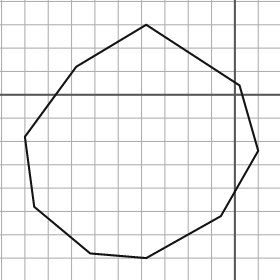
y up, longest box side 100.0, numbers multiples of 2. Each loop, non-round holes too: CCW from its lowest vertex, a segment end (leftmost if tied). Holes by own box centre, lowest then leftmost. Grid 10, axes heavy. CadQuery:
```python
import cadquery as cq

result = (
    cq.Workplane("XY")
    .moveTo(-38.0, -70.0)
    .lineTo(-6.0, -52.0)
    .lineTo(10.0, -24.0)
    .lineTo(2.0, 4.0)
    .lineTo(-38.0, 30.0)
    .lineTo(-68.0, 12.0)
    .lineTo(-90.0, -18.0)
    .lineTo(-86.0, -48.0)
    .lineTo(-62.0, -68.0)
    .close()
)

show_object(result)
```